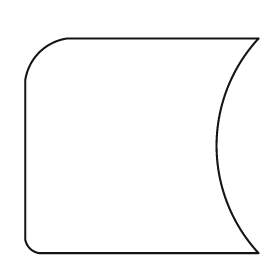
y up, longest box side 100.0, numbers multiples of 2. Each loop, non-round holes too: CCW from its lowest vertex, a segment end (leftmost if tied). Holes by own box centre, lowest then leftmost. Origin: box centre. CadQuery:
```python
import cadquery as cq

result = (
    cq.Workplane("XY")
    .moveTo(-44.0, -46.0)
    .lineTo(50.0, -46.0)
    .threePointArc((32.0, 0.0), (50.0, 46.0))
    .lineTo(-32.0, 46.0)
    .threePointArc((-44.0, 40.0), (-50.0, 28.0))
    .lineTo(-50.0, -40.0)
    .threePointArc((-48.0, -44.0), (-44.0, -46.0))
    .close()
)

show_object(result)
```